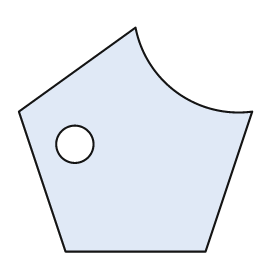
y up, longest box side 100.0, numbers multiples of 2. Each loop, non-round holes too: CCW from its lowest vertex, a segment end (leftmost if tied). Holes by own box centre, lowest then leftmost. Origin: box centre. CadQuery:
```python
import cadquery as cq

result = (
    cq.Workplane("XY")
    .moveTo(-30.0, -48.0)
    .lineTo(30.0, -48.0)
    .lineTo(50.0, 12.0)
    .threePointArc((18.0, 20.0), (0.0, 48.0))
    .lineTo(-50.0, 12.0)
    .close()
    .moveTo(-26.0, -2.0)
    .circle(8.0)
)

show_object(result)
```